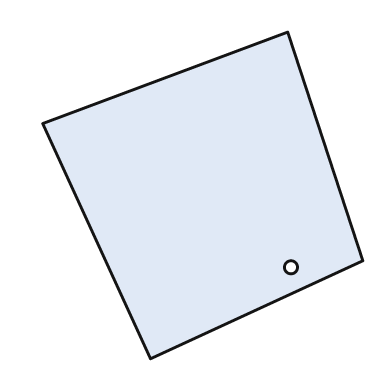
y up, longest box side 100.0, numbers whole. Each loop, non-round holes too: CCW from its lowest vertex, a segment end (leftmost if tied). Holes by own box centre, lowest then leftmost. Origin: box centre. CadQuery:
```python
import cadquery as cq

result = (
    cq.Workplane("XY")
    .moveTo(-16.0, -50.0)
    .lineTo(49.0, -20.0)
    .lineTo(26.0, 50.0)
    .lineTo(-49.0, 22.0)
    .close()
    .moveTo(27.0, -22.0)
    .circle(2.0)
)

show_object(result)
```